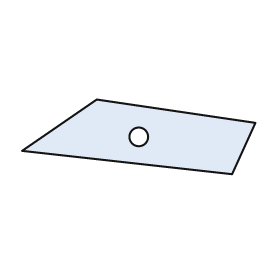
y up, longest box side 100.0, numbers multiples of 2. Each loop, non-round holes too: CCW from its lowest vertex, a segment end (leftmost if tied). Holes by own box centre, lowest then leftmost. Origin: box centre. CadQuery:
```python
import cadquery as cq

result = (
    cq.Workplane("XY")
    .moveTo(40.0, -16.0)
    .lineTo(50.0, 6.0)
    .lineTo(-18.0, 16.0)
    .lineTo(-50.0, -6.0)
    .close()
    .moveTo(0.0, 0.0)
    .circle(4.0)
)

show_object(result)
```